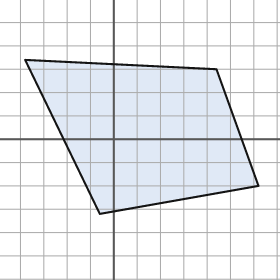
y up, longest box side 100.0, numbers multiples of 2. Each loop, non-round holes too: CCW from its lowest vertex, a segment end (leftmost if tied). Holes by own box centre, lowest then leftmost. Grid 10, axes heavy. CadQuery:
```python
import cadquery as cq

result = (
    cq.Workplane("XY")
    .moveTo(-6.0, -32.0)
    .lineTo(62.0, -20.0)
    .lineTo(44.0, 30.0)
    .lineTo(-38.0, 34.0)
    .close()
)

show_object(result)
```